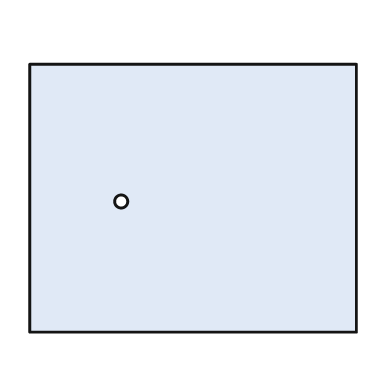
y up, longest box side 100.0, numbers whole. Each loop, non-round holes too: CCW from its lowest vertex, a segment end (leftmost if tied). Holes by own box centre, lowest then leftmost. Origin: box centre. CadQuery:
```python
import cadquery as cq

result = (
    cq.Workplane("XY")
    .moveTo(-50.0, -41.0)
    .lineTo(50.0, -41.0)
    .lineTo(50.0, 41.0)
    .lineTo(-50.0, 41.0)
    .close()
    .moveTo(-22.0, -1.0)
    .circle(2.0)
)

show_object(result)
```